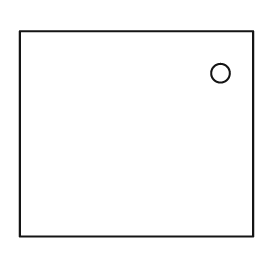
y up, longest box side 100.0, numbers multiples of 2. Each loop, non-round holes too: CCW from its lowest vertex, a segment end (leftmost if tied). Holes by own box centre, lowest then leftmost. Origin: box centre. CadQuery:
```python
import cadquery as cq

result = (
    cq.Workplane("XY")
    .moveTo(-50.0, -44.0)
    .lineTo(50.0, -44.0)
    .lineTo(50.0, 44.0)
    .lineTo(-50.0, 44.0)
    .close()
    .moveTo(36.0, 26.0)
    .circle(4.0)
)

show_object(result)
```